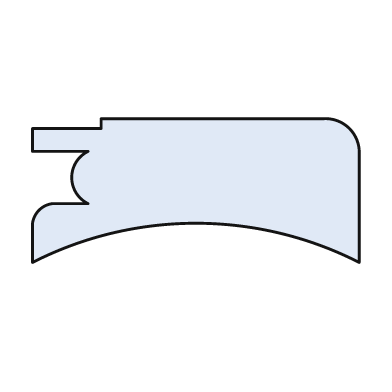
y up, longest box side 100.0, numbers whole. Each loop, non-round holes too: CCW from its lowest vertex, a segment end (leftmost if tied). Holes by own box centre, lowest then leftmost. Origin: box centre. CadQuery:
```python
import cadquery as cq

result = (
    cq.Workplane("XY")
    .moveTo(-50.0, -22.0)
    .threePointArc((0.0, -10.0), (50.0, -22.0))
    .lineTo(50.0, 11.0)
    .threePointArc((47.0, 19.0), (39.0, 22.0))
    .lineTo(-29.0, 22.0)
    .lineTo(-29.0, 19.0)
    .lineTo(-50.0, 19.0)
    .lineTo(-50.0, 12.0)
    .lineTo(-33.0, 12.0)
    .threePointArc((-38.0, 4.0), (-33.0, -4.0))
    .lineTo(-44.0, -4.0)
    .threePointArc((-48.0, -6.0), (-50.0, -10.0))
    .close()
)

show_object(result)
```